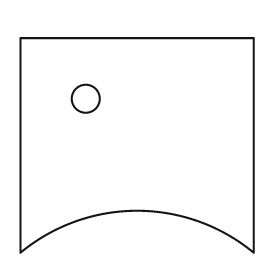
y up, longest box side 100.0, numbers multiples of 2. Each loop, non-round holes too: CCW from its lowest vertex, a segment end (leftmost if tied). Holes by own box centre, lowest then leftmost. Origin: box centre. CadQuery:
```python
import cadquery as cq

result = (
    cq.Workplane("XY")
    .moveTo(-50.0, -46.0)
    .threePointArc((0.0, -28.0), (50.0, -46.0))
    .lineTo(50.0, 46.0)
    .lineTo(-50.0, 46.0)
    .close()
    .moveTo(-22.0, 20.0)
    .circle(6.0)
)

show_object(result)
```